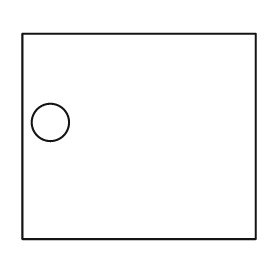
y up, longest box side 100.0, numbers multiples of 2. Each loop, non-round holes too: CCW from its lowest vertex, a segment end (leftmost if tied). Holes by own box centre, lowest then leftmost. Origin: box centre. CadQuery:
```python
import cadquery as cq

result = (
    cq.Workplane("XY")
    .moveTo(-50.0, -44.0)
    .lineTo(50.0, -44.0)
    .lineTo(50.0, 44.0)
    .lineTo(-50.0, 44.0)
    .close()
    .moveTo(-38.0, 6.0)
    .circle(8.0)
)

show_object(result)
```